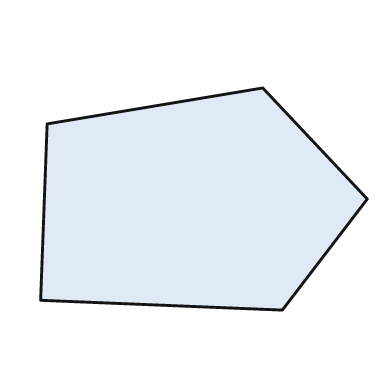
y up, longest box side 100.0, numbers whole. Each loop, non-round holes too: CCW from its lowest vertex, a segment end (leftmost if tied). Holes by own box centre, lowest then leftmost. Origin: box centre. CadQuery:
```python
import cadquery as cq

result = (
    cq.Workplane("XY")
    .moveTo(24.0, -34.0)
    .lineTo(50.0, 0.0)
    .lineTo(18.0, 34.0)
    .lineTo(-48.0, 23.0)
    .lineTo(-50.0, -31.0)
    .close()
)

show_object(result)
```